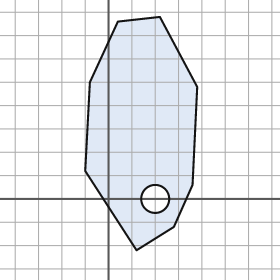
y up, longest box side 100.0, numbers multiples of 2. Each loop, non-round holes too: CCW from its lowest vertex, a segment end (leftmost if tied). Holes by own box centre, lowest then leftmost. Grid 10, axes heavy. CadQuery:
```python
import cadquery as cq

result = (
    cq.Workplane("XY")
    .moveTo(12.0, -22.0)
    .lineTo(28.0, -12.0)
    .lineTo(36.0, 6.0)
    .lineTo(38.0, 48.0)
    .lineTo(22.0, 78.0)
    .lineTo(4.0, 76.0)
    .lineTo(-8.0, 50.0)
    .lineTo(-10.0, 12.0)
    .close()
    .moveTo(20.0, 0.0)
    .circle(6.0)
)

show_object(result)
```